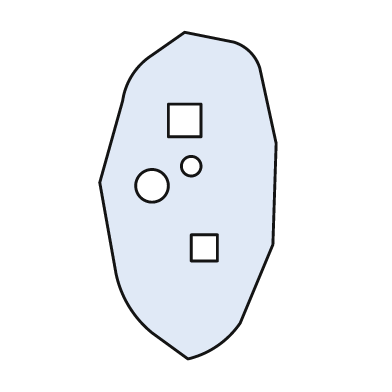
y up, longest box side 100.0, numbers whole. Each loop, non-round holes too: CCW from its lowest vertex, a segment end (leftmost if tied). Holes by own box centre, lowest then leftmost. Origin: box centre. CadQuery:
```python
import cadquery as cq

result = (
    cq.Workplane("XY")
    .moveTo(0.0, -50.0)
    .threePointArc((9.0, -46.0), (16.0, -39.0))
    .lineTo(26.0, -15.0)
    .lineTo(27.0, 16.0)
    .lineTo(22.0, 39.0)
    .threePointArc((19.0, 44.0), (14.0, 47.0))
    .lineTo(-1.0, 50.0)
    .lineTo(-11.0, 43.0)
    .threePointArc((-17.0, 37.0), (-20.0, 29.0))
    .lineTo(-27.0, 4.0)
    .lineTo(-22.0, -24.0)
    .threePointArc((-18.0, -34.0), (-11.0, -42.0))
    .close()
    .moveTo(1.0, -20.0)
    .lineTo(9.0, -20.0)
    .lineTo(9.0, -12.0)
    .lineTo(1.0, -12.0)
    .close()
    .moveTo(-11.0, 3.0)
    .circle(5.0)
    .moveTo(1.0, 9.0)
    .circle(3.0)
    .moveTo(-6.0, 18.0)
    .lineTo(4.0, 18.0)
    .lineTo(4.0, 28.0)
    .lineTo(-6.0, 28.0)
    .close()
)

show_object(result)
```